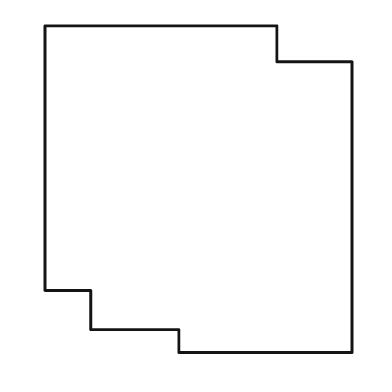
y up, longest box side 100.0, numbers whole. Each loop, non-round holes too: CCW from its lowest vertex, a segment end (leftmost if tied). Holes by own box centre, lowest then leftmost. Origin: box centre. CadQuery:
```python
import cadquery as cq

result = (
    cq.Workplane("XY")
    .moveTo(-6.0, -50.0)
    .lineTo(47.0, -50.0)
    .lineTo(47.0, 39.0)
    .lineTo(24.0, 39.0)
    .lineTo(24.0, 50.0)
    .lineTo(-47.0, 50.0)
    .lineTo(-47.0, -31.0)
    .lineTo(-33.0, -31.0)
    .lineTo(-33.0, -43.0)
    .lineTo(-6.0, -43.0)
    .close()
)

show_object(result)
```